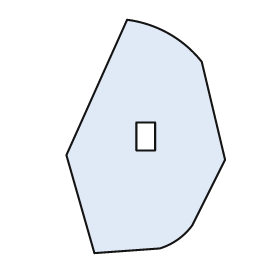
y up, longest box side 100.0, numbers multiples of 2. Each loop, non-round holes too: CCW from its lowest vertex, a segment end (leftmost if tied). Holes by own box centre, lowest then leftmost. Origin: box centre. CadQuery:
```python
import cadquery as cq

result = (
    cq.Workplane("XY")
    .moveTo(-22.0, -50.0)
    .lineTo(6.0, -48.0)
    .threePointArc((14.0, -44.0), (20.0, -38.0))
    .lineTo(34.0, -10.0)
    .lineTo(24.0, 32.0)
    .threePointArc((10.0, 44.0), (-8.0, 50.0))
    .lineTo(-34.0, -8.0)
    .close()
    .moveTo(-4.0, -6.0)
    .lineTo(4.0, -6.0)
    .lineTo(4.0, 6.0)
    .lineTo(-4.0, 6.0)
    .close()
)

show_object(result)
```